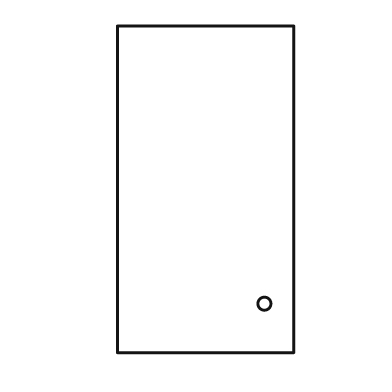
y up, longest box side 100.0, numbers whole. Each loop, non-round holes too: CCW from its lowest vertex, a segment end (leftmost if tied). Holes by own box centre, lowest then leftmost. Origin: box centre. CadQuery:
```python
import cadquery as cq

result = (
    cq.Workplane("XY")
    .moveTo(-27.0, -50.0)
    .lineTo(27.0, -50.0)
    .lineTo(27.0, 50.0)
    .lineTo(-27.0, 50.0)
    .close()
    .moveTo(18.0, -35.0)
    .circle(2.0)
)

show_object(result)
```